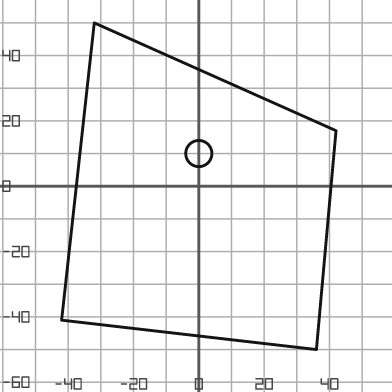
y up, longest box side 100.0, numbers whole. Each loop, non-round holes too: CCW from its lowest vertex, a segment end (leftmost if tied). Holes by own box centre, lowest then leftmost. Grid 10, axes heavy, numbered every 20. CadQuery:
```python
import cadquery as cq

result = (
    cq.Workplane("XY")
    .moveTo(36.0, -50.0)
    .lineTo(42.0, 17.0)
    .lineTo(-32.0, 50.0)
    .lineTo(-42.0, -41.0)
    .close()
    .moveTo(0.0, 10.0)
    .circle(4.0)
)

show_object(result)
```